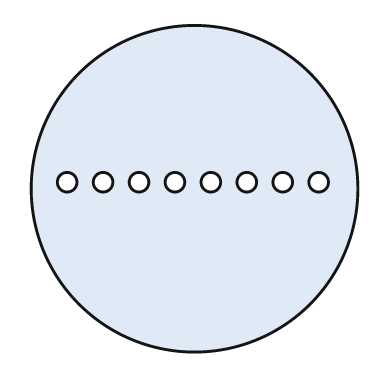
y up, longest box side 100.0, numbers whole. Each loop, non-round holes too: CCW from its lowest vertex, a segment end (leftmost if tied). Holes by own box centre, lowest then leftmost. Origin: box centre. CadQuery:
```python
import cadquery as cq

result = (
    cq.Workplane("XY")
    .moveTo(0.0, 0.0)
    .circle(50.0)
    .moveTo(-39.0, 2.0)
    .circle(3.0)
    .moveTo(-28.0, 2.0)
    .circle(3.0)
    .moveTo(-17.0, 2.0)
    .circle(3.0)
    .moveTo(-6.0, 2.0)
    .circle(3.0)
    .moveTo(5.0, 2.0)
    .circle(3.0)
    .moveTo(16.0, 2.0)
    .circle(3.0)
    .moveTo(27.0, 2.0)
    .circle(3.0)
    .moveTo(38.0, 2.0)
    .circle(3.0)
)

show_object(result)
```